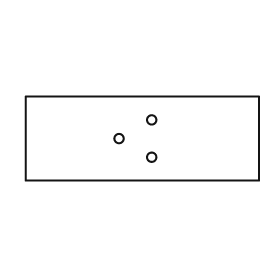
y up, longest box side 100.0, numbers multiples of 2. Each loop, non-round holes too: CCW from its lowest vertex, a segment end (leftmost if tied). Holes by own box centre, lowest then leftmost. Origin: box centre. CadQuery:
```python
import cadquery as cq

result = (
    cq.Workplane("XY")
    .moveTo(-50.0, -18.0)
    .lineTo(50.0, -18.0)
    .lineTo(50.0, 18.0)
    .lineTo(-50.0, 18.0)
    .close()
    .moveTo(4.0, -8.0)
    .circle(2.0)
    .moveTo(-10.0, 0.0)
    .circle(2.0)
    .moveTo(4.0, 8.0)
    .circle(2.0)
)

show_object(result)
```